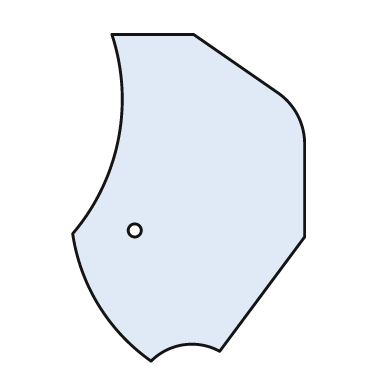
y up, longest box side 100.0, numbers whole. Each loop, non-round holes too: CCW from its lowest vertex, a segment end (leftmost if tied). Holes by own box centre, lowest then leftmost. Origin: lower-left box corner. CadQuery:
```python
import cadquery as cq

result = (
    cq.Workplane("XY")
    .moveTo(24.0, 0.0)
    .threePointArc((34.0, 5.0), (45.0, 3.0))
    .lineTo(71.0, 38.0)
    .lineTo(71.0, 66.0)
    .threePointArc((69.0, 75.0), (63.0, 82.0))
    .lineTo(37.0, 100.0)
    .lineTo(12.0, 100.0)
    .threePointArc((14.0, 68.0), (0.0, 39.0))
    .threePointArc((8.0, 17.0), (24.0, 0.0))
    .close()
    .moveTo(19.0, 40.0)
    .circle(2.0)
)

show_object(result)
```